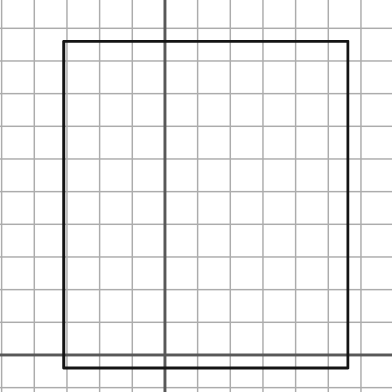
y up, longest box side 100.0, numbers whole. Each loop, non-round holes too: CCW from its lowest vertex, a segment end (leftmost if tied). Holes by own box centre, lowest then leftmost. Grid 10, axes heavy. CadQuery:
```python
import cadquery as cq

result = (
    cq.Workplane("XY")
    .moveTo(-31.0, -4.0)
    .lineTo(56.0, -4.0)
    .lineTo(56.0, 96.0)
    .lineTo(-31.0, 96.0)
    .close()
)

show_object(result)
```